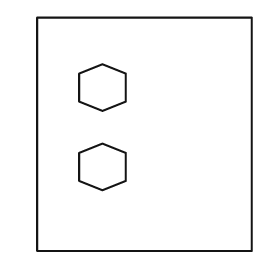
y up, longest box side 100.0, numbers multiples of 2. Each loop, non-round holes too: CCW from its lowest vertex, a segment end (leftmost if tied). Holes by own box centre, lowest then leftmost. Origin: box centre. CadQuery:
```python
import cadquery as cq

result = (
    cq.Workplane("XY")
    .moveTo(-46.0, -50.0)
    .lineTo(46.0, -50.0)
    .lineTo(46.0, 50.0)
    .lineTo(-46.0, 50.0)
    .close()
    .moveTo(-18.0, -24.0)
    .lineTo(-8.0, -20.0)
    .lineTo(-8.0, -8.0)
    .lineTo(-18.0, -4.0)
    .lineTo(-28.0, -8.0)
    .lineTo(-28.0, -20.0)
    .close()
    .moveTo(-18.0, 10.0)
    .lineTo(-8.0, 14.0)
    .lineTo(-8.0, 26.0)
    .lineTo(-18.0, 30.0)
    .lineTo(-28.0, 26.0)
    .lineTo(-28.0, 14.0)
    .close()
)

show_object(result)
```